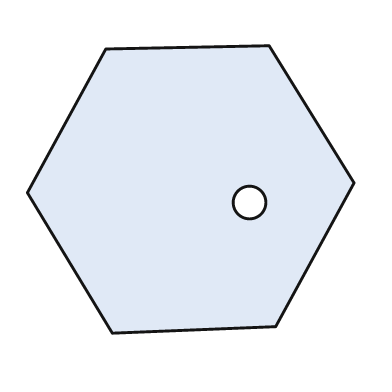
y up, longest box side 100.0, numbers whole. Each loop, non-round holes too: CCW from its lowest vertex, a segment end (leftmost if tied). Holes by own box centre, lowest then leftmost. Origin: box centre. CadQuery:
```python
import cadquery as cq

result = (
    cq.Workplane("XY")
    .moveTo(-24.0, -44.0)
    .lineTo(26.0, -42.0)
    .lineTo(50.0, 2.0)
    .lineTo(24.0, 44.0)
    .lineTo(-26.0, 43.0)
    .lineTo(-50.0, -1.0)
    .close()
    .moveTo(18.0, -4.0)
    .circle(5.0)
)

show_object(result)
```